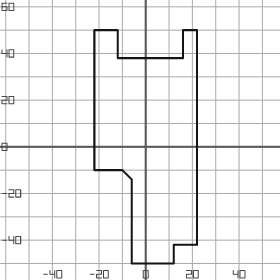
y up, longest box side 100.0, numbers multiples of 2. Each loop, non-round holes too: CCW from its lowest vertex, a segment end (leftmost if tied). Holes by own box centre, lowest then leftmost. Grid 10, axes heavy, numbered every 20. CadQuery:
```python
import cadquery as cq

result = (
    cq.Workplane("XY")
    .moveTo(-6.0, -50.0)
    .lineTo(12.0, -50.0)
    .lineTo(12.0, -42.0)
    .lineTo(22.0, -42.0)
    .lineTo(22.0, 50.0)
    .lineTo(16.0, 50.0)
    .lineTo(16.0, 38.0)
    .lineTo(-12.0, 38.0)
    .lineTo(-12.0, 50.0)
    .lineTo(-22.0, 50.0)
    .lineTo(-22.0, -10.0)
    .lineTo(-10.0, -10.0)
    .lineTo(-6.0, -14.0)
    .close()
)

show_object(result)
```